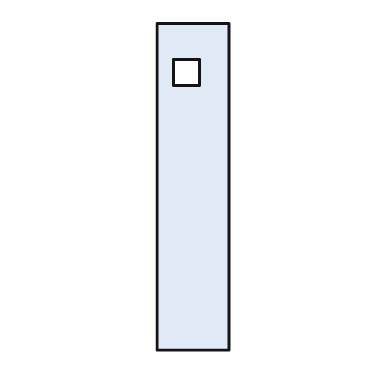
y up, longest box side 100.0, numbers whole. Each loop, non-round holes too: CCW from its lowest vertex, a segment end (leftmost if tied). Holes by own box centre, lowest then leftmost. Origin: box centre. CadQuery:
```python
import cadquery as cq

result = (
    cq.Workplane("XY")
    .moveTo(-11.0, -50.0)
    .lineTo(11.0, -50.0)
    .lineTo(11.0, 50.0)
    .lineTo(-11.0, 50.0)
    .close()
    .moveTo(-6.0, 31.0)
    .lineTo(2.0, 31.0)
    .lineTo(2.0, 39.0)
    .lineTo(-6.0, 39.0)
    .close()
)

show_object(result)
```